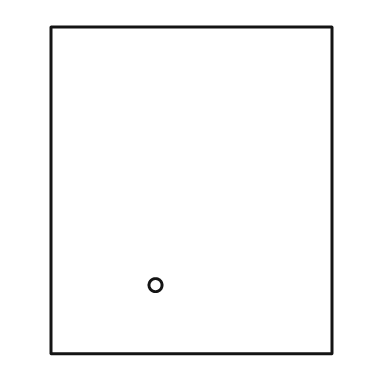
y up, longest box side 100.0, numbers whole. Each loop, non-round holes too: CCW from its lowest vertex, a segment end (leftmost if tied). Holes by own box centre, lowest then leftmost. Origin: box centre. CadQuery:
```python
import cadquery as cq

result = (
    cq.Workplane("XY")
    .moveTo(-43.0, -50.0)
    .lineTo(43.0, -50.0)
    .lineTo(43.0, 50.0)
    .lineTo(-43.0, 50.0)
    .close()
    .moveTo(-11.0, -29.0)
    .circle(2.0)
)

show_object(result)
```